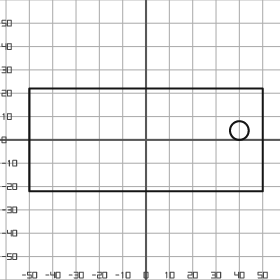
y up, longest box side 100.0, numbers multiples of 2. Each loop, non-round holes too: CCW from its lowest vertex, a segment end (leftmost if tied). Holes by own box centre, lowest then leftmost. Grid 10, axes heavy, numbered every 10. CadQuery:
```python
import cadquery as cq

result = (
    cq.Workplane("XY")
    .moveTo(-50.0, -22.0)
    .lineTo(50.0, -22.0)
    .lineTo(50.0, 22.0)
    .lineTo(-50.0, 22.0)
    .close()
    .moveTo(40.0, 4.0)
    .circle(4.0)
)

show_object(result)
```